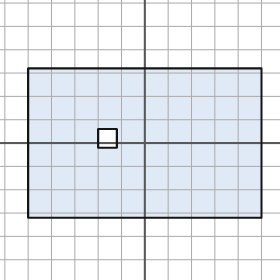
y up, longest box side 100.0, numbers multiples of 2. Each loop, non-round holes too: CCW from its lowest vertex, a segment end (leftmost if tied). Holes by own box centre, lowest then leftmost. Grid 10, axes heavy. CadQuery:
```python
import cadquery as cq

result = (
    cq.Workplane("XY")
    .moveTo(-50.0, -32.0)
    .lineTo(50.0, -32.0)
    .lineTo(50.0, 32.0)
    .lineTo(-50.0, 32.0)
    .close()
    .moveTo(-20.0, -2.0)
    .lineTo(-12.0, -2.0)
    .lineTo(-12.0, 6.0)
    .lineTo(-20.0, 6.0)
    .close()
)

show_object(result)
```